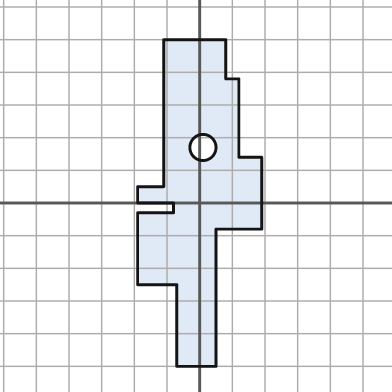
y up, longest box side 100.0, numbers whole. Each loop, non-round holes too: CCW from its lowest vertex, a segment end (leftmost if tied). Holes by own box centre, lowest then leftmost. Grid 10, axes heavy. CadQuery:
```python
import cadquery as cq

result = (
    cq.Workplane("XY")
    .moveTo(-7.0, -50.0)
    .lineTo(5.0, -50.0)
    .lineTo(5.0, -8.0)
    .lineTo(19.0, -8.0)
    .lineTo(19.0, 14.0)
    .lineTo(12.0, 14.0)
    .lineTo(12.0, 38.0)
    .lineTo(8.0, 38.0)
    .lineTo(8.0, 50.0)
    .lineTo(-11.0, 50.0)
    .lineTo(-11.0, 5.0)
    .lineTo(-19.0, 5.0)
    .lineTo(-19.0, 0.0)
    .lineTo(-8.0, 0.0)
    .lineTo(-8.0, -3.0)
    .lineTo(-19.0, -3.0)
    .lineTo(-19.0, -25.0)
    .lineTo(-7.0, -25.0)
    .close()
    .moveTo(1.0, 17.0)
    .circle(4.0)
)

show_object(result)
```